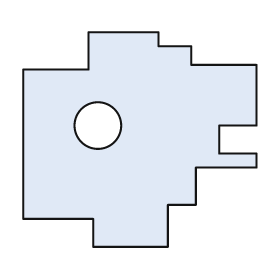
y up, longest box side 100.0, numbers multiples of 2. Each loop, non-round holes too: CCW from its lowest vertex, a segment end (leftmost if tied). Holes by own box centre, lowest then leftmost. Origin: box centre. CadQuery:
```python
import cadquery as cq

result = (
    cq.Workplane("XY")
    .moveTo(-20.0, -46.0)
    .lineTo(12.0, -46.0)
    .lineTo(12.0, -28.0)
    .lineTo(24.0, -28.0)
    .lineTo(24.0, -12.0)
    .lineTo(50.0, -12.0)
    .lineTo(50.0, -6.0)
    .lineTo(34.0, -6.0)
    .lineTo(34.0, 6.0)
    .lineTo(50.0, 6.0)
    .lineTo(50.0, 32.0)
    .lineTo(22.0, 32.0)
    .lineTo(22.0, 40.0)
    .lineTo(8.0, 40.0)
    .lineTo(8.0, 46.0)
    .lineTo(-22.0, 46.0)
    .lineTo(-22.0, 30.0)
    .lineTo(-50.0, 30.0)
    .lineTo(-50.0, -34.0)
    .lineTo(-20.0, -34.0)
    .close()
    .moveTo(-18.0, 6.0)
    .circle(10.0)
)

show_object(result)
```